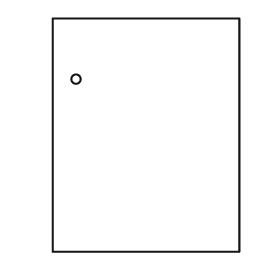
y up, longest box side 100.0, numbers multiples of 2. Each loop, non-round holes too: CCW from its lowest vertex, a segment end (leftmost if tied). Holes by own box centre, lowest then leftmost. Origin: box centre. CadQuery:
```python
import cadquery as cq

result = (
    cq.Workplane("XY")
    .moveTo(-40.0, -50.0)
    .lineTo(40.0, -50.0)
    .lineTo(40.0, 50.0)
    .lineTo(-40.0, 50.0)
    .close()
    .moveTo(-30.0, 24.0)
    .circle(2.0)
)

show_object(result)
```